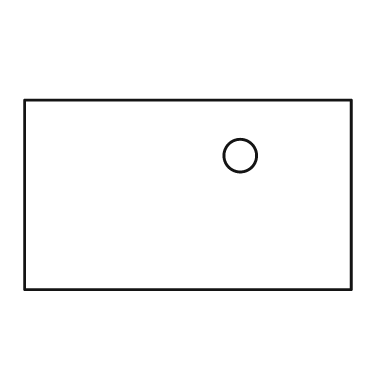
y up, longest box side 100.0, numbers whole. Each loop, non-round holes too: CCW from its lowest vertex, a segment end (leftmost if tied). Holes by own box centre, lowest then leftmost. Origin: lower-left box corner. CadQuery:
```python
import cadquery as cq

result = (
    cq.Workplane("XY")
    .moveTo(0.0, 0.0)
    .lineTo(100.0, 0.0)
    .lineTo(100.0, 58.0)
    .lineTo(0.0, 58.0)
    .close()
    .moveTo(66.0, 41.0)
    .circle(5.0)
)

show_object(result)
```